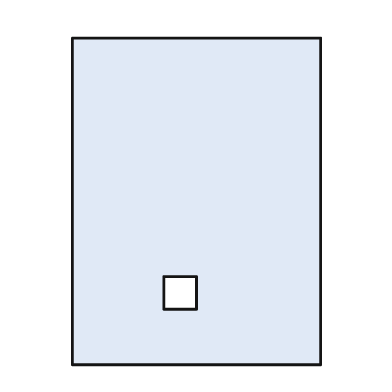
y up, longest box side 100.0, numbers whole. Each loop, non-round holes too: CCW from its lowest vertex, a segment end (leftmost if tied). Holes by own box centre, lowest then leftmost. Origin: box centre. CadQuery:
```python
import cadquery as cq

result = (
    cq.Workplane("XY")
    .moveTo(-38.0, -50.0)
    .lineTo(38.0, -50.0)
    .lineTo(38.0, 50.0)
    .lineTo(-38.0, 50.0)
    .close()
    .moveTo(-10.0, -33.0)
    .lineTo(0.0, -33.0)
    .lineTo(0.0, -23.0)
    .lineTo(-10.0, -23.0)
    .close()
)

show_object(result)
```